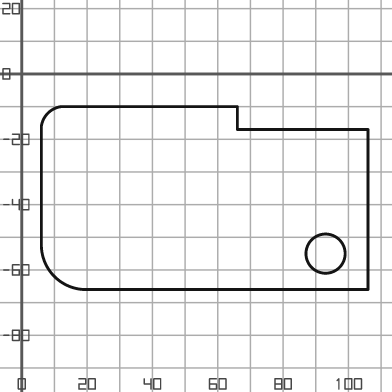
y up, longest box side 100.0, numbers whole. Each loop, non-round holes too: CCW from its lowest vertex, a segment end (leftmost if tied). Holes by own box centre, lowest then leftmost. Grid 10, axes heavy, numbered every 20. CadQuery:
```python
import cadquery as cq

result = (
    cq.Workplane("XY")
    .moveTo(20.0, -66.0)
    .lineTo(106.0, -66.0)
    .lineTo(106.0, -17.0)
    .lineTo(66.0, -17.0)
    .lineTo(66.0, -10.0)
    .lineTo(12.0, -10.0)
    .threePointArc((8.0, -12.0), (6.0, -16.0))
    .lineTo(6.0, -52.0)
    .threePointArc((10.0, -62.0), (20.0, -66.0))
    .close()
    .moveTo(93.0, -55.0)
    .circle(6.0)
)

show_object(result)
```